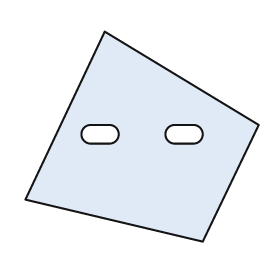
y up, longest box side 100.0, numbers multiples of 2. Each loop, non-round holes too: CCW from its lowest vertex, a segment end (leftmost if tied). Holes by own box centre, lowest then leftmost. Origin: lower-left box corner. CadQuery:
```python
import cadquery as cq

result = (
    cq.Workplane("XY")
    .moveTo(76.0, 0.0)
    .lineTo(100.0, 50.0)
    .lineTo(34.0, 90.0)
    .lineTo(0.0, 18.0)
    .close()
    .moveTo(28.0, 42.0)
    .lineTo(36.0, 42.0)
    .threePointArc((40.0, 46.0), (36.0, 50.0))
    .lineTo(28.0, 50.0)
    .threePointArc((24.0, 46.0), (28.0, 42.0))
    .close()
    .moveTo(64.0, 42.0)
    .lineTo(72.0, 42.0)
    .threePointArc((76.0, 46.0), (72.0, 50.0))
    .lineTo(64.0, 50.0)
    .threePointArc((60.0, 46.0), (64.0, 42.0))
    .close()
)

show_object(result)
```